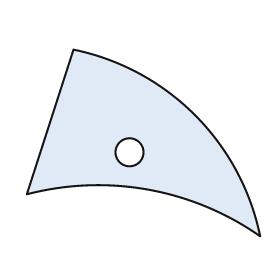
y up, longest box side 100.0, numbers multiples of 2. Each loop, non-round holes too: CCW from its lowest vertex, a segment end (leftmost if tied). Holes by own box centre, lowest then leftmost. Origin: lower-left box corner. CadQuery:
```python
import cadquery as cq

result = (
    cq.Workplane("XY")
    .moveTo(100.0, 0.0)
    .threePointArc((72.0, 52.0), (20.0, 80.0))
    .lineTo(0.0, 18.0)
    .threePointArc((52.0, 20.0), (100.0, 0.0))
    .close()
    .moveTo(44.0, 36.0)
    .circle(6.0)
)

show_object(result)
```